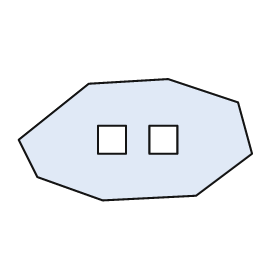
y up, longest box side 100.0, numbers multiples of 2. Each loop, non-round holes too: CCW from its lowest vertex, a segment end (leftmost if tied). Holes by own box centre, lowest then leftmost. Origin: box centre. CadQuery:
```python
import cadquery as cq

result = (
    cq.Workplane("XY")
    .moveTo(-14.0, -26.0)
    .lineTo(26.0, -24.0)
    .lineTo(50.0, -6.0)
    .lineTo(44.0, 16.0)
    .lineTo(14.0, 26.0)
    .lineTo(-20.0, 24.0)
    .lineTo(-50.0, 0.0)
    .lineTo(-42.0, -16.0)
    .close()
    .moveTo(-16.0, -6.0)
    .lineTo(-4.0, -6.0)
    .lineTo(-4.0, 6.0)
    .lineTo(-16.0, 6.0)
    .close()
    .moveTo(6.0, -6.0)
    .lineTo(18.0, -6.0)
    .lineTo(18.0, 6.0)
    .lineTo(6.0, 6.0)
    .close()
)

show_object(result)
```